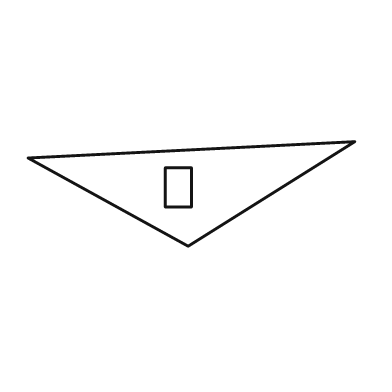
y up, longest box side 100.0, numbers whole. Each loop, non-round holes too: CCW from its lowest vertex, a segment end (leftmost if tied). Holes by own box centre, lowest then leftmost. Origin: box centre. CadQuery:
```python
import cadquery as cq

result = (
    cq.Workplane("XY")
    .moveTo(-1.0, -16.0)
    .lineTo(50.0, 16.0)
    .lineTo(-50.0, 11.0)
    .close()
    .moveTo(-8.0, -4.0)
    .lineTo(0.0, -4.0)
    .lineTo(0.0, 8.0)
    .lineTo(-8.0, 8.0)
    .close()
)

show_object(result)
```